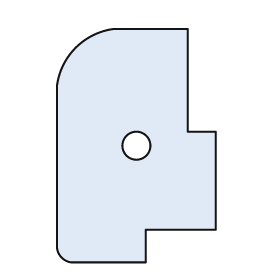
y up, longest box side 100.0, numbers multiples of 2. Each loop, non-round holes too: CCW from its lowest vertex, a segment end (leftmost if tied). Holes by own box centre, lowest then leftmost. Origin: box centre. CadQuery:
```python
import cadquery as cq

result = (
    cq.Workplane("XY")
    .moveTo(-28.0, -50.0)
    .lineTo(4.0, -50.0)
    .lineTo(4.0, -36.0)
    .lineTo(34.0, -36.0)
    .lineTo(34.0, 6.0)
    .lineTo(22.0, 6.0)
    .lineTo(22.0, 50.0)
    .lineTo(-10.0, 50.0)
    .threePointArc((-26.0, 42.0), (-34.0, 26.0))
    .lineTo(-34.0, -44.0)
    .threePointArc((-32.0, -48.0), (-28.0, -50.0))
    .close()
    .moveTo(0.0, 0.0)
    .circle(6.0)
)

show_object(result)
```